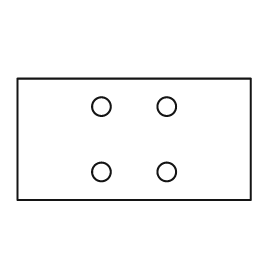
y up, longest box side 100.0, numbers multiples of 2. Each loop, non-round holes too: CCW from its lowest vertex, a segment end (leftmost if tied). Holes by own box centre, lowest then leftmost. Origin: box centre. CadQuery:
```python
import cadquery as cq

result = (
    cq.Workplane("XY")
    .moveTo(-50.0, -26.0)
    .lineTo(50.0, -26.0)
    .lineTo(50.0, 26.0)
    .lineTo(-50.0, 26.0)
    .close()
    .moveTo(-14.0, -14.0)
    .circle(4.0)
    .moveTo(14.0, -14.0)
    .circle(4.0)
    .moveTo(-14.0, 14.0)
    .circle(4.0)
    .moveTo(14.0, 14.0)
    .circle(4.0)
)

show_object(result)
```